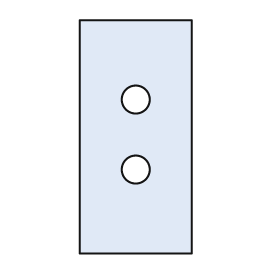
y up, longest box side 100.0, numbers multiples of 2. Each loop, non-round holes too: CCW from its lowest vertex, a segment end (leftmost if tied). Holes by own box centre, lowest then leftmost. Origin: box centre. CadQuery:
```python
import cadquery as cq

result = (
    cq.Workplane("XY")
    .moveTo(-24.0, -50.0)
    .lineTo(24.0, -50.0)
    .lineTo(24.0, 50.0)
    .lineTo(-24.0, 50.0)
    .close()
    .moveTo(0.0, -14.0)
    .circle(6.0)
    .moveTo(0.0, 16.0)
    .circle(6.0)
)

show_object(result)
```